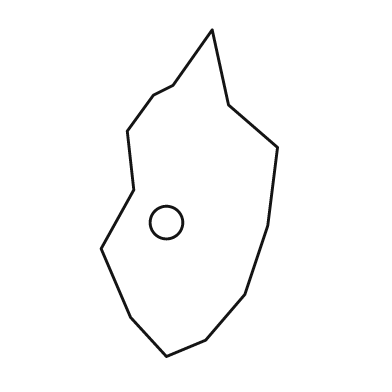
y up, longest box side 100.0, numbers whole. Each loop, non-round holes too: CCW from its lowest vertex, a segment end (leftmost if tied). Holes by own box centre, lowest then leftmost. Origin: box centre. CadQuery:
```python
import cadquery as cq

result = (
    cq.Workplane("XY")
    .moveTo(-7.0, -50.0)
    .lineTo(5.0, -45.0)
    .lineTo(17.0, -31.0)
    .lineTo(24.0, -10.0)
    .lineTo(27.0, 14.0)
    .lineTo(12.0, 27.0)
    .lineTo(7.0, 50.0)
    .lineTo(-5.0, 33.0)
    .lineTo(-11.0, 30.0)
    .lineTo(-19.0, 19.0)
    .lineTo(-17.0, 1.0)
    .lineTo(-27.0, -17.0)
    .lineTo(-18.0, -38.0)
    .close()
    .moveTo(-7.0, -9.0)
    .circle(5.0)
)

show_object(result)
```